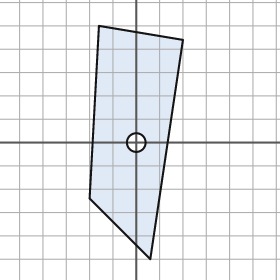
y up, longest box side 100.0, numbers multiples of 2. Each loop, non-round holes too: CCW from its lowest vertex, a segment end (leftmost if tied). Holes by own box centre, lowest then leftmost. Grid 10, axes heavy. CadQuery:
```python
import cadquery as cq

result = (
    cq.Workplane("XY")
    .moveTo(6.0, -50.0)
    .lineTo(20.0, 44.0)
    .lineTo(-16.0, 50.0)
    .lineTo(-20.0, -24.0)
    .close()
    .moveTo(0.0, 0.0)
    .circle(4.0)
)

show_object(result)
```